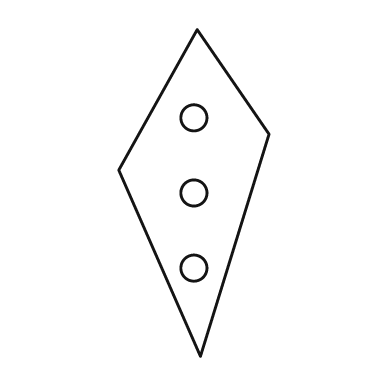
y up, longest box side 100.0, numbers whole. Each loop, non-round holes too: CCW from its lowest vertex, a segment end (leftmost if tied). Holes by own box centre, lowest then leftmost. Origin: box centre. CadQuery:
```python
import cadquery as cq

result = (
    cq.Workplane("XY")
    .moveTo(2.0, -50.0)
    .lineTo(23.0, 18.0)
    .lineTo(1.0, 50.0)
    .lineTo(-23.0, 7.0)
    .close()
    .moveTo(0.0, -23.0)
    .circle(4.0)
    .moveTo(0.0, 0.0)
    .circle(4.0)
    .moveTo(0.0, 23.0)
    .circle(4.0)
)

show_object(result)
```